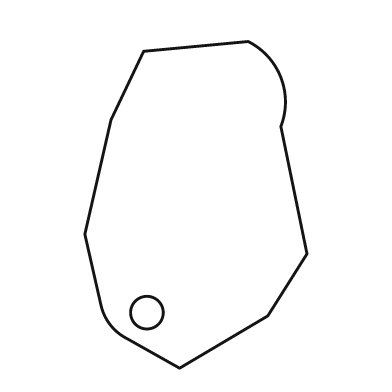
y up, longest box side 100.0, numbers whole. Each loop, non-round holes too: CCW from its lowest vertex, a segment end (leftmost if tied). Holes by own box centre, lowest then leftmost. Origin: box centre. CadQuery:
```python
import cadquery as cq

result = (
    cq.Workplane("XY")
    .moveTo(-5.0, -50.0)
    .lineTo(22.0, -34.0)
    .lineTo(34.0, -15.0)
    .lineTo(26.0, 24.0)
    .threePointArc((26.0, 39.0), (16.0, 50.0))
    .lineTo(-16.0, 47.0)
    .lineTo(-26.0, 26.0)
    .lineTo(-34.0, -9.0)
    .lineTo(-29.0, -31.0)
    .threePointArc((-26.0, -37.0), (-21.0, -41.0))
    .close()
    .moveTo(-15.0, -33.0)
    .circle(5.0)
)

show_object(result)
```